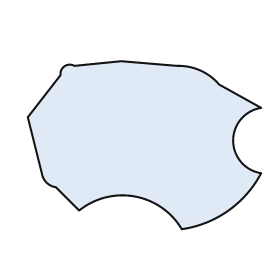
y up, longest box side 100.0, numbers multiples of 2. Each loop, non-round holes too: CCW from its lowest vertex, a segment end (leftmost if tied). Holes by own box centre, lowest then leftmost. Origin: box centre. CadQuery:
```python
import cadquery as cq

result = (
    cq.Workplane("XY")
    .moveTo(16.0, -36.0)
    .threePointArc((36.0, -28.0), (50.0, -12.0))
    .threePointArc((38.0, 2.0), (50.0, 16.0))
    .lineTo(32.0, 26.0)
    .threePointArc((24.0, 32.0), (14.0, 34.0))
    .lineTo(-10.0, 36.0)
    .lineTo(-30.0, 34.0)
    .threePointArc((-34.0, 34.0), (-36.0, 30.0))
    .lineTo(-50.0, 12.0)
    .lineTo(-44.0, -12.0)
    .threePointArc((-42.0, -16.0), (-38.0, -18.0))
    .lineTo(-28.0, -28.0)
    .threePointArc((-4.0, -22.0), (16.0, -36.0))
    .close()
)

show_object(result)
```